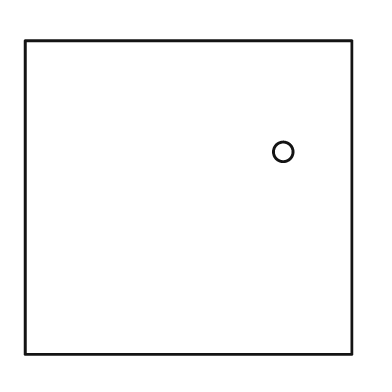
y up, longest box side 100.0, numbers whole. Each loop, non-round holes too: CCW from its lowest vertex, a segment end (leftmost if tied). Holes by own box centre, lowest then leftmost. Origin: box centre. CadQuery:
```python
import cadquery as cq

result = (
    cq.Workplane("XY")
    .moveTo(-50.0, -48.0)
    .lineTo(50.0, -48.0)
    .lineTo(50.0, 48.0)
    .lineTo(-50.0, 48.0)
    .close()
    .moveTo(29.0, 14.0)
    .circle(3.0)
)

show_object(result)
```